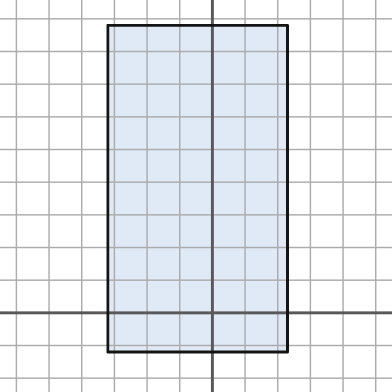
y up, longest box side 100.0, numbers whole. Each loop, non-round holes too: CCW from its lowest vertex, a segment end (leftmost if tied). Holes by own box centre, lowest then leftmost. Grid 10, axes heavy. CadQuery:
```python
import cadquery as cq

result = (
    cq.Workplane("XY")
    .moveTo(-32.0, -12.0)
    .lineTo(23.0, -12.0)
    .lineTo(23.0, 88.0)
    .lineTo(-32.0, 88.0)
    .close()
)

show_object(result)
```